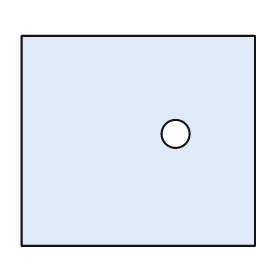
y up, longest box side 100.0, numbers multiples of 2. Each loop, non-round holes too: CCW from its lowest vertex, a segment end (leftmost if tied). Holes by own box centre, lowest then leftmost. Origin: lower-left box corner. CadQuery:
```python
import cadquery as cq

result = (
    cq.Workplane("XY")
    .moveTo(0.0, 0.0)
    .lineTo(100.0, 0.0)
    .lineTo(100.0, 90.0)
    .lineTo(0.0, 90.0)
    .close()
    .moveTo(66.0, 48.0)
    .circle(6.0)
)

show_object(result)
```